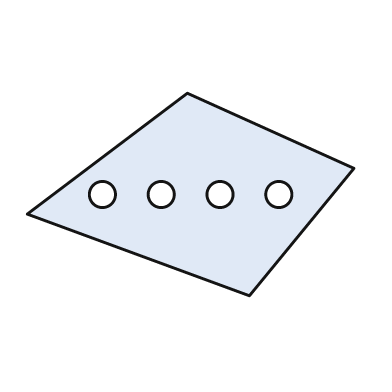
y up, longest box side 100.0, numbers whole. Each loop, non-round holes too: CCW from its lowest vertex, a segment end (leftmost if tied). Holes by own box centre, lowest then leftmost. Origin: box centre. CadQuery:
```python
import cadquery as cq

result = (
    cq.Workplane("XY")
    .moveTo(18.0, -31.0)
    .lineTo(50.0, 8.0)
    .lineTo(-1.0, 31.0)
    .lineTo(-50.0, -6.0)
    .close()
    .moveTo(-27.0, 0.0)
    .circle(4.0)
    .moveTo(-9.0, 0.0)
    .circle(4.0)
    .moveTo(9.0, 0.0)
    .circle(4.0)
    .moveTo(27.0, 0.0)
    .circle(4.0)
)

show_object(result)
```